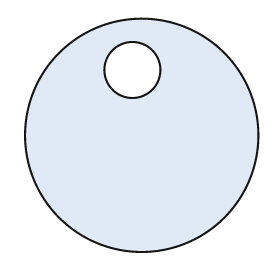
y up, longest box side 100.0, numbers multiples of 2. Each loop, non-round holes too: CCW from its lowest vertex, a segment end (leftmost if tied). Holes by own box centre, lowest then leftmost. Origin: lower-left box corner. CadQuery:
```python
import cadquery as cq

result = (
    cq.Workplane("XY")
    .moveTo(50.0, 50.0)
    .circle(50.0)
    .moveTo(46.0, 78.0)
    .circle(12.0)
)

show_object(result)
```